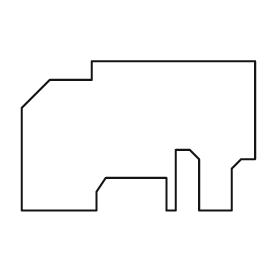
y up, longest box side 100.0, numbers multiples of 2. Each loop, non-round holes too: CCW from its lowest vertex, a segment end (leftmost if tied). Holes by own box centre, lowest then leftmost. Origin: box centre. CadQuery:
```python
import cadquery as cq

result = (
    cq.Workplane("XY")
    .moveTo(-50.0, -32.0)
    .lineTo(-18.0, -32.0)
    .lineTo(-18.0, -24.0)
    .lineTo(-14.0, -18.0)
    .lineTo(12.0, -18.0)
    .lineTo(12.0, -32.0)
    .lineTo(16.0, -32.0)
    .lineTo(16.0, -6.0)
    .lineTo(22.0, -6.0)
    .lineTo(26.0, -10.0)
    .lineTo(26.0, -32.0)
    .lineTo(40.0, -32.0)
    .lineTo(40.0, -14.0)
    .lineTo(44.0, -10.0)
    .lineTo(50.0, -10.0)
    .lineTo(50.0, 32.0)
    .lineTo(-20.0, 32.0)
    .lineTo(-20.0, 24.0)
    .lineTo(-38.0, 24.0)
    .lineTo(-50.0, 12.0)
    .close()
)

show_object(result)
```